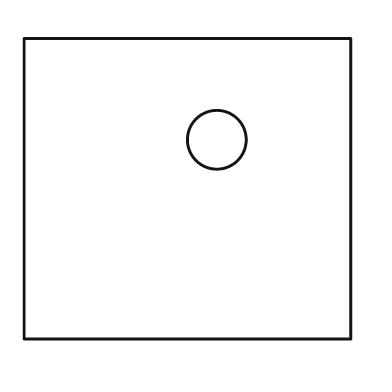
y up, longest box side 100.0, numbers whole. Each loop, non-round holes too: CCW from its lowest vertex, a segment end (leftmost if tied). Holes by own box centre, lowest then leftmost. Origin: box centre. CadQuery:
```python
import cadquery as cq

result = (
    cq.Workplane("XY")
    .moveTo(-50.0, -46.0)
    .lineTo(50.0, -46.0)
    .lineTo(50.0, 46.0)
    .lineTo(-50.0, 46.0)
    .close()
    .moveTo(9.0, 15.0)
    .circle(9.0)
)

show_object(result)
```